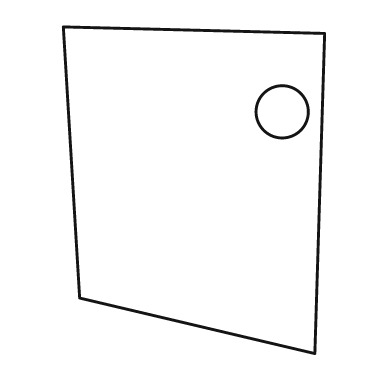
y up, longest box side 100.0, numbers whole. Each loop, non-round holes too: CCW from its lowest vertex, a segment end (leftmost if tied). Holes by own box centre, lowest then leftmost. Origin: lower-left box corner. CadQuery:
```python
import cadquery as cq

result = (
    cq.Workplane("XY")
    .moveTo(77.0, 0.0)
    .lineTo(80.0, 98.0)
    .lineTo(0.0, 100.0)
    .lineTo(5.0, 17.0)
    .close()
    .moveTo(67.0, 74.0)
    .circle(8.0)
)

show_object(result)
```